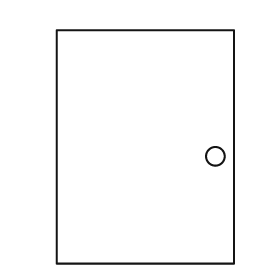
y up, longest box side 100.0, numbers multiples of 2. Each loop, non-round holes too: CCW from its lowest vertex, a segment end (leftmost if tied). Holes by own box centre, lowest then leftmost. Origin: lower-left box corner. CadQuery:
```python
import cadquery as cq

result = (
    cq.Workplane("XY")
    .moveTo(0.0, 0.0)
    .lineTo(76.0, 0.0)
    .lineTo(76.0, 100.0)
    .lineTo(0.0, 100.0)
    .close()
    .moveTo(68.0, 46.0)
    .circle(4.0)
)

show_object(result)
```